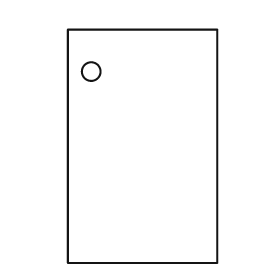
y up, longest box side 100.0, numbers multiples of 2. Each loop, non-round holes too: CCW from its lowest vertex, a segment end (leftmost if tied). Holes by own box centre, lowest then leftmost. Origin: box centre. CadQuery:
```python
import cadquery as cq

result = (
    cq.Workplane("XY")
    .moveTo(-32.0, -50.0)
    .lineTo(32.0, -50.0)
    .lineTo(32.0, 50.0)
    .lineTo(-32.0, 50.0)
    .close()
    .moveTo(-22.0, 32.0)
    .circle(4.0)
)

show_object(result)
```